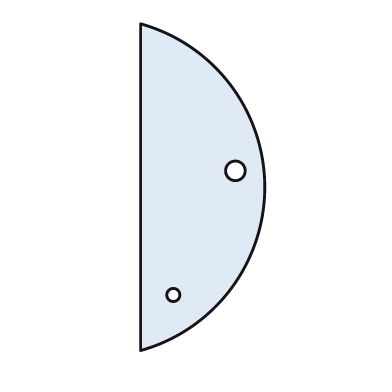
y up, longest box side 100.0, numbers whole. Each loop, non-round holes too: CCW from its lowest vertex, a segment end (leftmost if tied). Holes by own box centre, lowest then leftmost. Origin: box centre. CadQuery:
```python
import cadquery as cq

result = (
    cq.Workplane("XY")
    .moveTo(-19.0, -50.0)
    .threePointArc((19.0, 0.0), (-19.0, 50.0))
    .close()
    .moveTo(-9.0, -33.0)
    .circle(2.0)
    .moveTo(10.0, 5.0)
    .circle(3.0)
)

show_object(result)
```